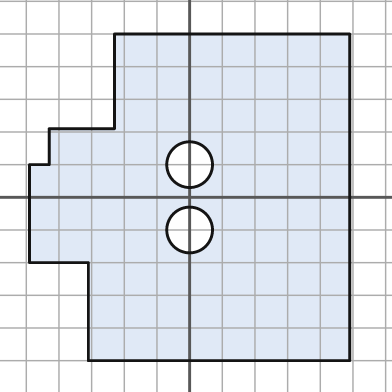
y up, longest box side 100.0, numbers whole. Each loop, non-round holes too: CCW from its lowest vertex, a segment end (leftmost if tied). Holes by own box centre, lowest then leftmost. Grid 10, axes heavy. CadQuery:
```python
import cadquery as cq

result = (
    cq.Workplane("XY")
    .moveTo(-31.0, -50.0)
    .lineTo(49.0, -50.0)
    .lineTo(49.0, 50.0)
    .lineTo(-23.0, 50.0)
    .lineTo(-23.0, 21.0)
    .lineTo(-43.0, 21.0)
    .lineTo(-43.0, 10.0)
    .lineTo(-49.0, 10.0)
    .lineTo(-49.0, -20.0)
    .lineTo(-31.0, -20.0)
    .close()
    .moveTo(0.0, -10.0)
    .circle(7.0)
    .moveTo(0.0, 10.0)
    .circle(7.0)
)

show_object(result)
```